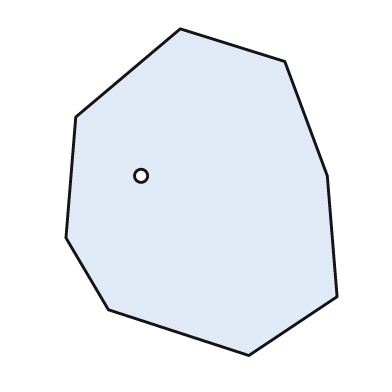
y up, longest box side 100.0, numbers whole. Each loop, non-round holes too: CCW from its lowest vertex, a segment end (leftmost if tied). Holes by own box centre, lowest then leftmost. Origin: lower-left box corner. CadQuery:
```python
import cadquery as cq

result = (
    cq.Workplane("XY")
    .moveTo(56.0, 0.0)
    .lineTo(83.0, 18.0)
    .lineTo(80.0, 55.0)
    .lineTo(67.0, 90.0)
    .lineTo(35.0, 100.0)
    .lineTo(3.0, 73.0)
    .lineTo(0.0, 36.0)
    .lineTo(13.0, 14.0)
    .close()
    .moveTo(23.0, 55.0)
    .circle(2.0)
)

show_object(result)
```